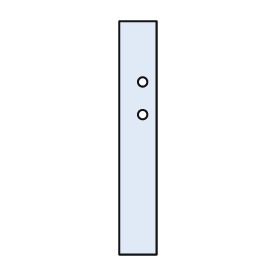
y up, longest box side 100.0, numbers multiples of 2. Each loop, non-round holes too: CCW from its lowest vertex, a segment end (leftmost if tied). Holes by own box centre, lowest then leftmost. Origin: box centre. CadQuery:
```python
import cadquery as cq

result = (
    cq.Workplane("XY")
    .moveTo(-8.0, -50.0)
    .lineTo(8.0, -50.0)
    .lineTo(8.0, 50.0)
    .lineTo(-8.0, 50.0)
    .close()
    .moveTo(2.0, 10.0)
    .circle(2.0)
    .moveTo(2.0, 24.0)
    .circle(2.0)
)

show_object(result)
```